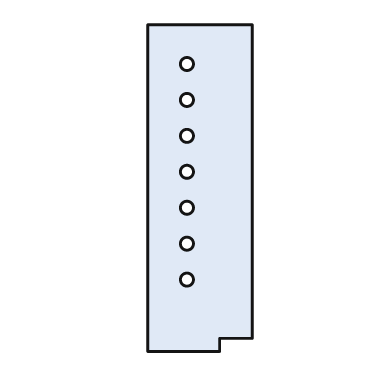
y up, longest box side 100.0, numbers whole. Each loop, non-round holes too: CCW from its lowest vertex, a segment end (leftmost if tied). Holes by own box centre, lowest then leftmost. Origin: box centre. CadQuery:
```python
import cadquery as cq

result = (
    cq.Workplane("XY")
    .moveTo(-16.0, -50.0)
    .lineTo(6.0, -50.0)
    .lineTo(6.0, -46.0)
    .lineTo(16.0, -46.0)
    .lineTo(16.0, 50.0)
    .lineTo(-16.0, 50.0)
    .close()
    .moveTo(-4.0, -28.0)
    .circle(2.0)
    .moveTo(-4.0, -17.0)
    .circle(2.0)
    .moveTo(-4.0, -6.0)
    .circle(2.0)
    .moveTo(-4.0, 5.0)
    .circle(2.0)
    .moveTo(-4.0, 16.0)
    .circle(2.0)
    .moveTo(-4.0, 27.0)
    .circle(2.0)
    .moveTo(-4.0, 38.0)
    .circle(2.0)
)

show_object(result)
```